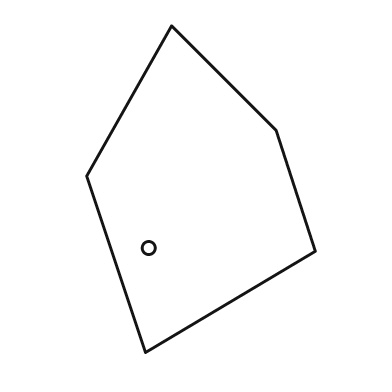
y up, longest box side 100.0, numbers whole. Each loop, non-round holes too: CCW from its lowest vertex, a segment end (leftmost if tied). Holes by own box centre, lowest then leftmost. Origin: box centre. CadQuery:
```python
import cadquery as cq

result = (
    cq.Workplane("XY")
    .moveTo(-17.0, -50.0)
    .lineTo(35.0, -19.0)
    .lineTo(23.0, 18.0)
    .lineTo(-9.0, 50.0)
    .lineTo(-35.0, 4.0)
    .close()
    .moveTo(-16.0, -18.0)
    .circle(2.0)
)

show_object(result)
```